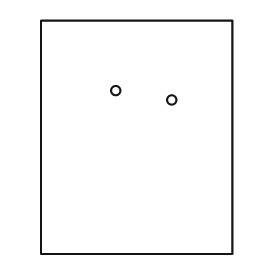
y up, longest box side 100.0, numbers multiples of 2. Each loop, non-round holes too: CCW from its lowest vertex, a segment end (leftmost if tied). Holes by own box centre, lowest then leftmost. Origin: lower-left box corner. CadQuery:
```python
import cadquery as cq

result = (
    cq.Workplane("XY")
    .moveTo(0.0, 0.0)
    .lineTo(82.0, 0.0)
    .lineTo(82.0, 100.0)
    .lineTo(0.0, 100.0)
    .close()
    .moveTo(56.0, 66.0)
    .circle(2.0)
    .moveTo(32.0, 70.0)
    .circle(2.0)
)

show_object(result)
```